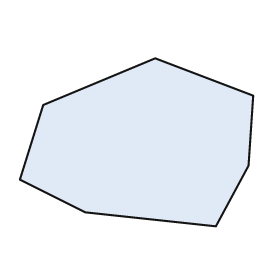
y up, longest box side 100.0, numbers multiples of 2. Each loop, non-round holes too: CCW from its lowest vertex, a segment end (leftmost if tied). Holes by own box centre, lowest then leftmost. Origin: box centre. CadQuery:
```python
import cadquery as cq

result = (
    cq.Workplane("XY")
    .moveTo(34.0, -36.0)
    .lineTo(48.0, -10.0)
    .lineTo(50.0, 20.0)
    .lineTo(8.0, 36.0)
    .lineTo(-40.0, 16.0)
    .lineTo(-50.0, -16.0)
    .lineTo(-22.0, -30.0)
    .close()
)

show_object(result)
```